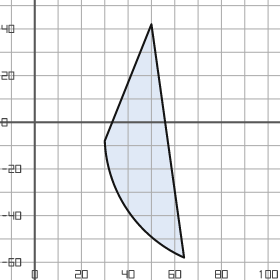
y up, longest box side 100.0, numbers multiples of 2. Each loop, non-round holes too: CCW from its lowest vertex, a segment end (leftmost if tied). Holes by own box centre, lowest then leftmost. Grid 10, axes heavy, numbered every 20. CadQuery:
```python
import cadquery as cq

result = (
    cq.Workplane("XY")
    .moveTo(64.0, -58.0)
    .lineTo(50.0, 42.0)
    .lineTo(30.0, -8.0)
    .threePointArc((40.0, -38.0), (64.0, -58.0))
    .close()
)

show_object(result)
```